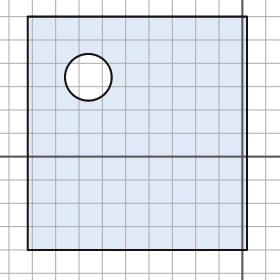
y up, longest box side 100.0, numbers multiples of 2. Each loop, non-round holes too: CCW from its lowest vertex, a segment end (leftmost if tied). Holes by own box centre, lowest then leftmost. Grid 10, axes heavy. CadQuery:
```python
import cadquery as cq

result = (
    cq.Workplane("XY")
    .moveTo(-92.0, -40.0)
    .lineTo(2.0, -40.0)
    .lineTo(2.0, 60.0)
    .lineTo(-92.0, 60.0)
    .close()
    .moveTo(-66.0, 34.0)
    .circle(10.0)
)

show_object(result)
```